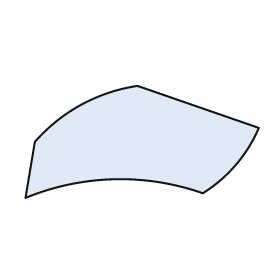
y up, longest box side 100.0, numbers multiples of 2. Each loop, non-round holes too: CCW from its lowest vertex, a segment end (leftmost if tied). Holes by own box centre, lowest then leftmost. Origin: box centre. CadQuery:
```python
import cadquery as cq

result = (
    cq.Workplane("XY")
    .moveTo(-50.0, -24.0)
    .threePointArc((-12.0, -16.0), (26.0, -22.0))
    .threePointArc((40.0, -10.0), (50.0, 6.0))
    .lineTo(-2.0, 24.0)
    .threePointArc((-26.0, 16.0), (-46.0, 0.0))
    .close()
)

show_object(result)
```